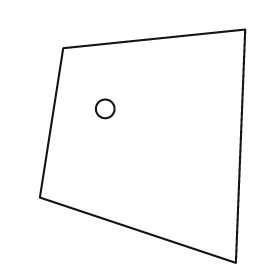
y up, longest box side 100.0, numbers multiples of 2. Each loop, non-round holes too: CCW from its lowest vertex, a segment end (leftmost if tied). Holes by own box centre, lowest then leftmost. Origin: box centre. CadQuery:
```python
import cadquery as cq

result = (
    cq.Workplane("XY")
    .moveTo(40.0, -50.0)
    .lineTo(44.0, 50.0)
    .lineTo(-34.0, 42.0)
    .lineTo(-44.0, -22.0)
    .close()
    .moveTo(-16.0, 16.0)
    .circle(4.0)
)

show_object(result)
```